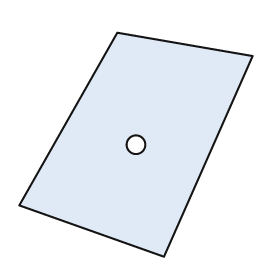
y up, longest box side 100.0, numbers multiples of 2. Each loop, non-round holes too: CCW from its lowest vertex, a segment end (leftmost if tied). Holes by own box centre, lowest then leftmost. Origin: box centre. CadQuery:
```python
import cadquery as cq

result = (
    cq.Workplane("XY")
    .moveTo(12.0, -48.0)
    .lineTo(50.0, 38.0)
    .lineTo(-8.0, 48.0)
    .lineTo(-50.0, -26.0)
    .close()
    .moveTo(0.0, 0.0)
    .circle(4.0)
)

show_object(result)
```